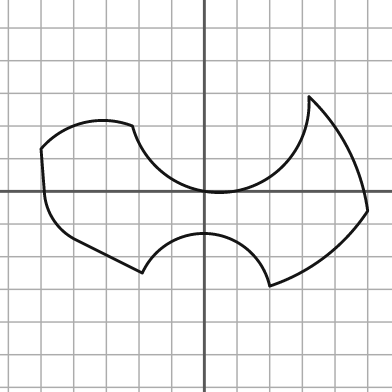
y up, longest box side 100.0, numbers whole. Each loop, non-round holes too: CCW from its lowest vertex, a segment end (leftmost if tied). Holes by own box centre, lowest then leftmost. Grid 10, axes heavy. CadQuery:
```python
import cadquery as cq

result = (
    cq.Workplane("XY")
    .moveTo(20.0, -29.0)
    .threePointArc((37.0, -20.0), (50.0, -6.0))
    .threePointArc((44.0, 13.0), (32.0, 29.0))
    .threePointArc((9.0, 0.0), (-22.0, 20.0))
    .threePointArc((-37.0, 21.0), (-50.0, 13.0))
    .lineTo(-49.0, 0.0)
    .threePointArc((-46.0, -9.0), (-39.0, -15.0))
    .lineTo(-19.0, -25.0)
    .threePointArc((2.0, -13.0), (20.0, -29.0))
    .close()
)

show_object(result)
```